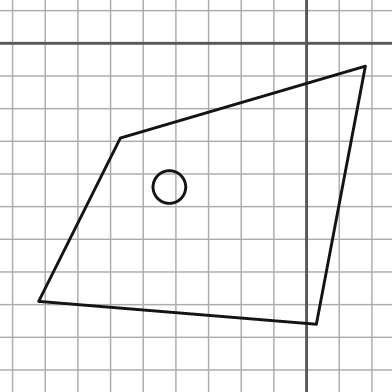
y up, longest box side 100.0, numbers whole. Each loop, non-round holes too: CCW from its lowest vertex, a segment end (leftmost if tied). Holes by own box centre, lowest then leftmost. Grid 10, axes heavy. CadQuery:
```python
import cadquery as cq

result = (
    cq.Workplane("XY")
    .moveTo(3.0, -86.0)
    .lineTo(18.0, -7.0)
    .lineTo(-57.0, -29.0)
    .lineTo(-82.0, -79.0)
    .close()
    .moveTo(-42.0, -44.0)
    .circle(5.0)
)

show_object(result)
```